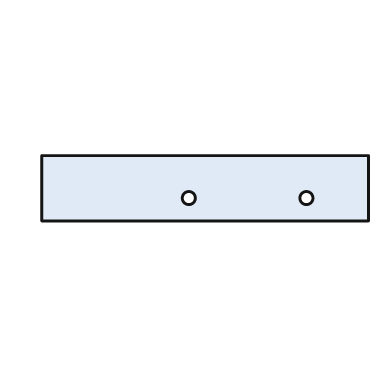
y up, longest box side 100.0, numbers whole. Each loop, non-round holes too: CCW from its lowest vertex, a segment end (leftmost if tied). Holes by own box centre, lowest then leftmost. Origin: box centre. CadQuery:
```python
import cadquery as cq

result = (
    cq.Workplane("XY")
    .moveTo(-50.0, -10.0)
    .lineTo(50.0, -10.0)
    .lineTo(50.0, 10.0)
    .lineTo(-50.0, 10.0)
    .close()
    .moveTo(-5.0, -3.0)
    .circle(2.0)
    .moveTo(31.0, -3.0)
    .circle(2.0)
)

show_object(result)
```